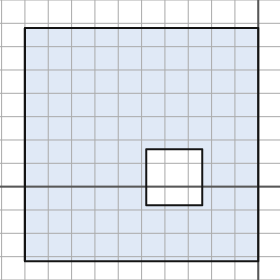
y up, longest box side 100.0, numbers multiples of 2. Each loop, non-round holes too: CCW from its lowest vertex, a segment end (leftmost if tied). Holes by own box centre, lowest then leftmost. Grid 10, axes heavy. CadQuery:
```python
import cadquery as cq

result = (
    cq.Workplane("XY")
    .moveTo(-100.0, -32.0)
    .lineTo(0.0, -32.0)
    .lineTo(0.0, 68.0)
    .lineTo(-100.0, 68.0)
    .close()
    .moveTo(-48.0, -8.0)
    .lineTo(-24.0, -8.0)
    .lineTo(-24.0, 16.0)
    .lineTo(-48.0, 16.0)
    .close()
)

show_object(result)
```